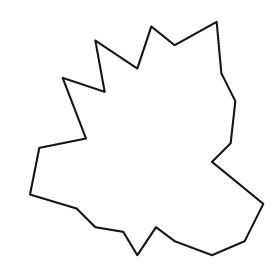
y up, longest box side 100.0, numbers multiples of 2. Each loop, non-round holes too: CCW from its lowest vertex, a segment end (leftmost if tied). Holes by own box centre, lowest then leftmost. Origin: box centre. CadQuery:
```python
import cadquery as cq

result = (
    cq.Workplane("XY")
    .moveTo(-4.0, -50.0)
    .lineTo(4.0, -38.0)
    .lineTo(12.0, -44.0)
    .lineTo(28.0, -50.0)
    .lineTo(42.0, -44.0)
    .lineTo(50.0, -28.0)
    .lineTo(28.0, -10.0)
    .lineTo(36.0, -2.0)
    .lineTo(38.0, 16.0)
    .lineTo(32.0, 28.0)
    .lineTo(30.0, 50.0)
    .lineTo(12.0, 40.0)
    .lineTo(2.0, 48.0)
    .lineTo(-4.0, 30.0)
    .lineTo(-22.0, 42.0)
    .lineTo(-18.0, 20.0)
    .lineTo(-36.0, 26.0)
    .lineTo(-26.0, 0.0)
    .lineTo(-46.0, -4.0)
    .lineTo(-50.0, -24.0)
    .lineTo(-30.0, -30.0)
    .lineTo(-22.0, -38.0)
    .lineTo(-10.0, -40.0)
    .close()
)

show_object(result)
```